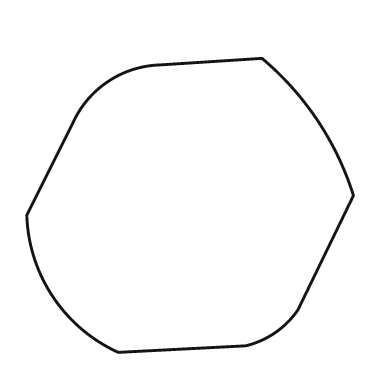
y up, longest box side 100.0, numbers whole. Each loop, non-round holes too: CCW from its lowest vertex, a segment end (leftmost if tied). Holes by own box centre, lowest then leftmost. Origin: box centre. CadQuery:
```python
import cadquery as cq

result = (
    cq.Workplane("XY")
    .moveTo(-22.0, -45.0)
    .lineTo(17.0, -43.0)
    .threePointArc((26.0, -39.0), (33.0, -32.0))
    .lineTo(50.0, 3.0)
    .threePointArc((39.0, 26.0), (22.0, 45.0))
    .lineTo(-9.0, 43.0)
    .threePointArc((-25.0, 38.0), (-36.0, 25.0))
    .lineTo(-50.0, -3.0)
    .threePointArc((-42.0, -28.0), (-22.0, -45.0))
    .close()
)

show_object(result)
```